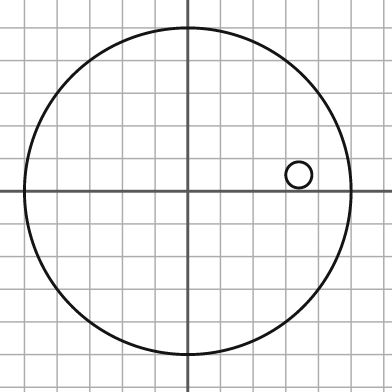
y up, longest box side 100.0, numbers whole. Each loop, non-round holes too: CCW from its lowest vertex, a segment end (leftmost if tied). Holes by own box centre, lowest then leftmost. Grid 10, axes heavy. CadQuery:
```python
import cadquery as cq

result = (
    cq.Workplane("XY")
    .moveTo(0.0, 0.0)
    .circle(50.0)
    .moveTo(34.0, 5.0)
    .circle(4.0)
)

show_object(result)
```